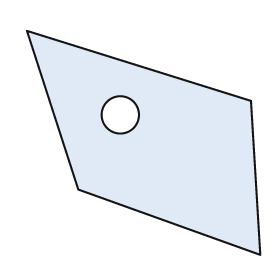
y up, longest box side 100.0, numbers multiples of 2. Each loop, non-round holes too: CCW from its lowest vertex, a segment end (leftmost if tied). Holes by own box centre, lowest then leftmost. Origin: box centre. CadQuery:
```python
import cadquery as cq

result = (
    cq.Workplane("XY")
    .moveTo(50.0, -48.0)
    .lineTo(46.0, 18.0)
    .lineTo(-50.0, 48.0)
    .lineTo(-28.0, -20.0)
    .close()
    .moveTo(-10.0, 12.0)
    .circle(8.0)
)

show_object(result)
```